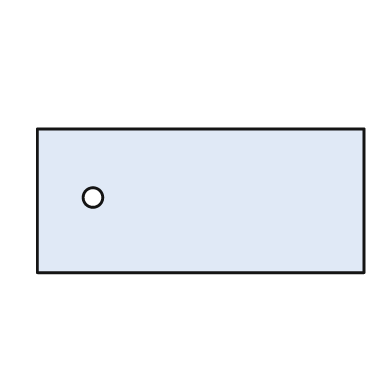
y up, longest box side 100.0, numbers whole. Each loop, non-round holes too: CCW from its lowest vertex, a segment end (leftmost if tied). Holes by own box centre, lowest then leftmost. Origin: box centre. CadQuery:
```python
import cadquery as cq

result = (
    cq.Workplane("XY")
    .moveTo(-50.0, -22.0)
    .lineTo(50.0, -22.0)
    .lineTo(50.0, 22.0)
    .lineTo(-50.0, 22.0)
    .close()
    .moveTo(-33.0, 1.0)
    .circle(3.0)
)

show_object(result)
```